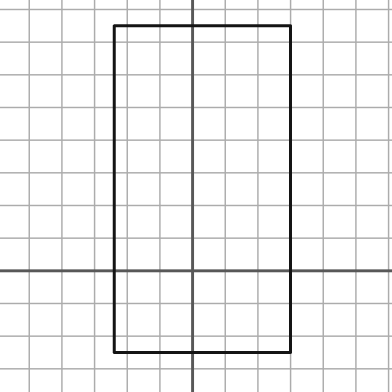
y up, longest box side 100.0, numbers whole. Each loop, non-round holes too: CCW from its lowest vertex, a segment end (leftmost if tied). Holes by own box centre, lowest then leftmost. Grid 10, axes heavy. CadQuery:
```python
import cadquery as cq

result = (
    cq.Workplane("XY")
    .moveTo(-24.0, -25.0)
    .lineTo(30.0, -25.0)
    .lineTo(30.0, 75.0)
    .lineTo(-24.0, 75.0)
    .close()
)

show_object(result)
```